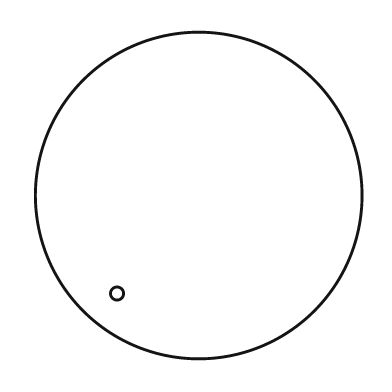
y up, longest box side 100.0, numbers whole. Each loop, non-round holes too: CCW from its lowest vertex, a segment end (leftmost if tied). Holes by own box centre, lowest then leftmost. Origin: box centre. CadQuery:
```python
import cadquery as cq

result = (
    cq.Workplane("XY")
    .moveTo(0.0, 0.0)
    .circle(50.0)
    .moveTo(-25.0, -30.0)
    .circle(2.0)
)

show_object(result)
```